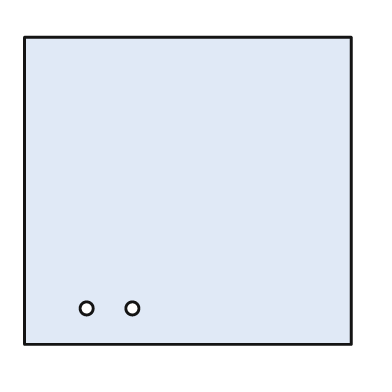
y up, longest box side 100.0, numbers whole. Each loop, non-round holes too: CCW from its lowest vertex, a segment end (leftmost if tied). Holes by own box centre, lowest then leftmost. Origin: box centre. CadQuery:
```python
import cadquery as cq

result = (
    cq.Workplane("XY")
    .moveTo(-50.0, -47.0)
    .lineTo(50.0, -47.0)
    .lineTo(50.0, 47.0)
    .lineTo(-50.0, 47.0)
    .close()
    .moveTo(-31.0, -36.0)
    .circle(2.0)
    .moveTo(-17.0, -36.0)
    .circle(2.0)
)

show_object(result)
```